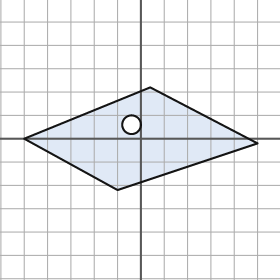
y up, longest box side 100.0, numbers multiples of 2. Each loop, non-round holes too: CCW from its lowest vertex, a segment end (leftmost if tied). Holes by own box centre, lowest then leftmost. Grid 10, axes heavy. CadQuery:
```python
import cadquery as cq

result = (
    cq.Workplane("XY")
    .moveTo(-10.0, -22.0)
    .lineTo(50.0, -2.0)
    .lineTo(4.0, 22.0)
    .lineTo(-50.0, 0.0)
    .close()
    .moveTo(-4.0, 6.0)
    .circle(4.0)
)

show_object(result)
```